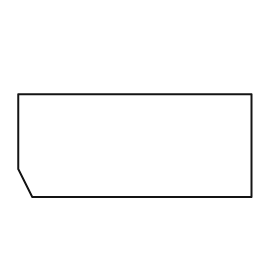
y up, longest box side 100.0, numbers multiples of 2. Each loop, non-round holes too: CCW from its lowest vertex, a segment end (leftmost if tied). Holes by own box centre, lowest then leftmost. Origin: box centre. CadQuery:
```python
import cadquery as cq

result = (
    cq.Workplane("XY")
    .moveTo(-44.0, -22.0)
    .lineTo(50.0, -22.0)
    .lineTo(50.0, 22.0)
    .lineTo(-50.0, 22.0)
    .lineTo(-50.0, -10.0)
    .close()
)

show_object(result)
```